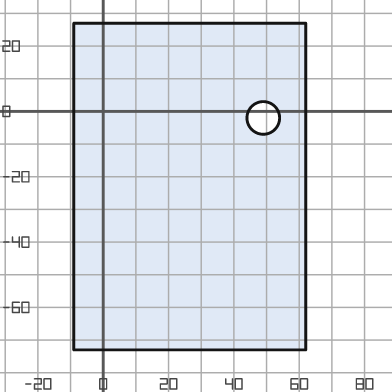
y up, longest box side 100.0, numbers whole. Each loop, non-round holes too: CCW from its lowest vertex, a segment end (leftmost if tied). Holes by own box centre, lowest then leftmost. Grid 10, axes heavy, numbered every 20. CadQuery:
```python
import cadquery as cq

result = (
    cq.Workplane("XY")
    .moveTo(-9.0, -73.0)
    .lineTo(62.0, -73.0)
    .lineTo(62.0, 27.0)
    .lineTo(-9.0, 27.0)
    .close()
    .moveTo(49.0, -2.0)
    .circle(5.0)
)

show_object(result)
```